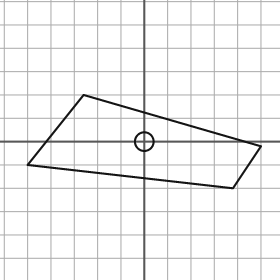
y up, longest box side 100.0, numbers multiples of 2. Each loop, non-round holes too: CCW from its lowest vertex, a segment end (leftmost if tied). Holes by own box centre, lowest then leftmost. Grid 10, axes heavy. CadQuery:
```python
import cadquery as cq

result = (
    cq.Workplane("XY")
    .moveTo(38.0, -20.0)
    .lineTo(50.0, -2.0)
    .lineTo(-26.0, 20.0)
    .lineTo(-50.0, -10.0)
    .close()
    .moveTo(0.0, 0.0)
    .circle(4.0)
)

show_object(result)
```